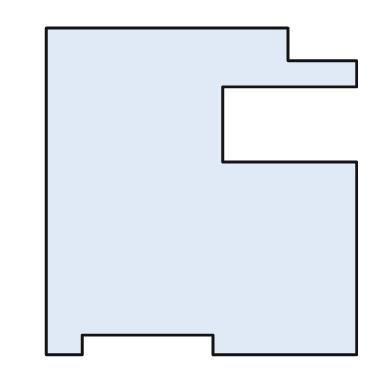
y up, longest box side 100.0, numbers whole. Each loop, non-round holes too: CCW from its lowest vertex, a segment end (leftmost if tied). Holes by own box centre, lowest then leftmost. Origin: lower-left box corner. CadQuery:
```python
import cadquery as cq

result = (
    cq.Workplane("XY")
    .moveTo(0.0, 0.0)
    .lineTo(11.0, 0.0)
    .lineTo(11.0, 6.0)
    .lineTo(51.0, 6.0)
    .lineTo(51.0, 0.0)
    .lineTo(95.0, 0.0)
    .lineTo(95.0, 59.0)
    .lineTo(54.0, 59.0)
    .lineTo(54.0, 82.0)
    .lineTo(95.0, 82.0)
    .lineTo(95.0, 90.0)
    .lineTo(74.0, 90.0)
    .lineTo(74.0, 100.0)
    .lineTo(0.0, 100.0)
    .close()
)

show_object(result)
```